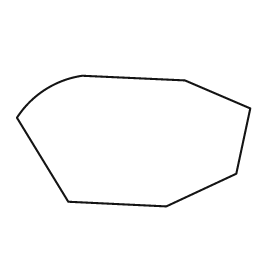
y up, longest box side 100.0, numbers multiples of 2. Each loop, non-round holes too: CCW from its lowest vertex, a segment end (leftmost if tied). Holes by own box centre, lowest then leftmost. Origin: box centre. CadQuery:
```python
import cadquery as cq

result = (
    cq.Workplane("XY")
    .moveTo(14.0, -28.0)
    .lineTo(44.0, -14.0)
    .lineTo(50.0, 14.0)
    .lineTo(22.0, 26.0)
    .lineTo(-22.0, 28.0)
    .threePointArc((-38.0, 22.0), (-50.0, 10.0))
    .lineTo(-28.0, -26.0)
    .close()
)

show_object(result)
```